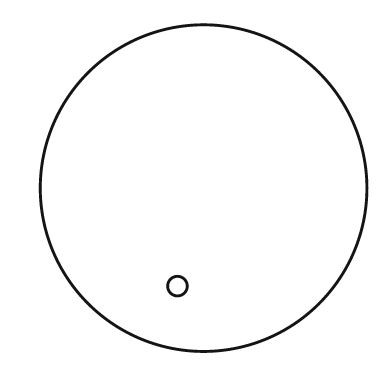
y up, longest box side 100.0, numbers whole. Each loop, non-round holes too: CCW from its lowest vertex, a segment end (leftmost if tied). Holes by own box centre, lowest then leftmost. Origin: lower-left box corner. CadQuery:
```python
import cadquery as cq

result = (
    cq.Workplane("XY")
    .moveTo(50.0, 50.0)
    .circle(50.0)
    .moveTo(42.0, 20.0)
    .circle(3.0)
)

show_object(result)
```